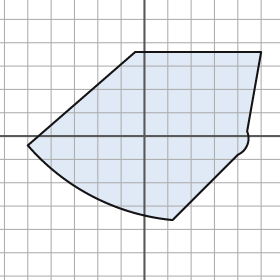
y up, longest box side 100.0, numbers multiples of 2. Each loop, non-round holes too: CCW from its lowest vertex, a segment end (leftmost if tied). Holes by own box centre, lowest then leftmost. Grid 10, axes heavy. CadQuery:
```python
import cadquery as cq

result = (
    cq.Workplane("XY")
    .moveTo(12.0, -36.0)
    .lineTo(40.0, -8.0)
    .threePointArc((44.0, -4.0), (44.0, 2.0))
    .lineTo(50.0, 36.0)
    .lineTo(-4.0, 36.0)
    .lineTo(-50.0, -4.0)
    .threePointArc((-22.0, -26.0), (12.0, -36.0))
    .close()
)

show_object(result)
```